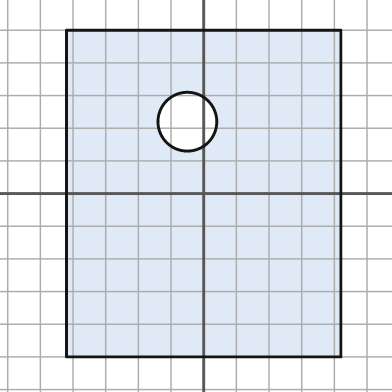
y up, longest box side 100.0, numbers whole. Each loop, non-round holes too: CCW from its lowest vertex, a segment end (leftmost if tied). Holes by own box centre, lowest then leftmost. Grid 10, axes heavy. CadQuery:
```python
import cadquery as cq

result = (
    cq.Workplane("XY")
    .moveTo(-42.0, -50.0)
    .lineTo(42.0, -50.0)
    .lineTo(42.0, 50.0)
    .lineTo(-42.0, 50.0)
    .close()
    .moveTo(-5.0, 22.0)
    .circle(9.0)
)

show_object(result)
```